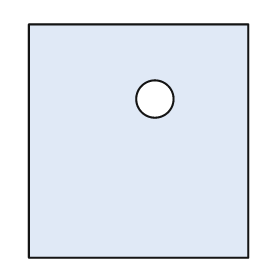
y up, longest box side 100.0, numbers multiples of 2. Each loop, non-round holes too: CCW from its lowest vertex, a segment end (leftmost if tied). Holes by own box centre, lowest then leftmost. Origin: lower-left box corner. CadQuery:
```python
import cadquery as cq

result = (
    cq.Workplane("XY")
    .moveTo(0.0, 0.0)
    .lineTo(94.0, 0.0)
    .lineTo(94.0, 100.0)
    .lineTo(0.0, 100.0)
    .close()
    .moveTo(54.0, 68.0)
    .circle(8.0)
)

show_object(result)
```